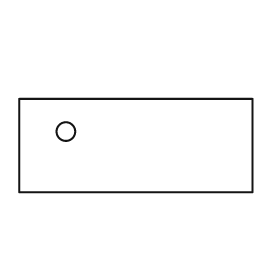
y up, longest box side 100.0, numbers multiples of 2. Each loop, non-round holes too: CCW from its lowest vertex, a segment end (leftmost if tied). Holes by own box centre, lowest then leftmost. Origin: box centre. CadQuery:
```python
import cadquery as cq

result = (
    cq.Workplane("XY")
    .moveTo(-50.0, -20.0)
    .lineTo(50.0, -20.0)
    .lineTo(50.0, 20.0)
    .lineTo(-50.0, 20.0)
    .close()
    .moveTo(-30.0, 6.0)
    .circle(4.0)
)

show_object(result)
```